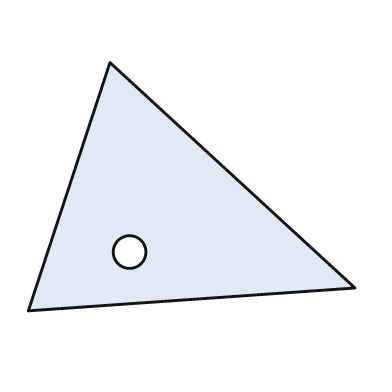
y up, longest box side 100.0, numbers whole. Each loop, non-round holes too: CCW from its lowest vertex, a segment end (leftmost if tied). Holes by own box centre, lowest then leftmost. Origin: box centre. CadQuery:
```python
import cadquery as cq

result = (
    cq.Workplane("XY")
    .moveTo(-50.0, -38.0)
    .lineTo(50.0, -31.0)
    .lineTo(-25.0, 38.0)
    .close()
    .moveTo(-19.0, -20.0)
    .circle(5.0)
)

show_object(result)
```